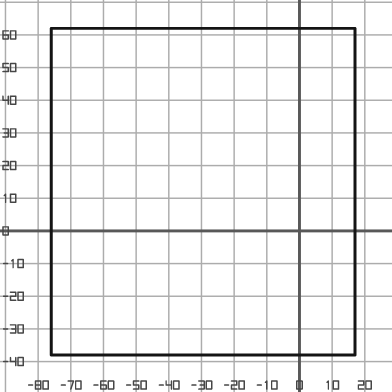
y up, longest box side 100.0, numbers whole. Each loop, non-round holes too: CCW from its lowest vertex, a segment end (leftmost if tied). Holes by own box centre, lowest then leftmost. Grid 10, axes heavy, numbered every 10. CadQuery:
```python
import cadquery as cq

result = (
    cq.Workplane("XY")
    .moveTo(-76.0, -38.0)
    .lineTo(17.0, -38.0)
    .lineTo(17.0, 62.0)
    .lineTo(-76.0, 62.0)
    .close()
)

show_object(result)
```